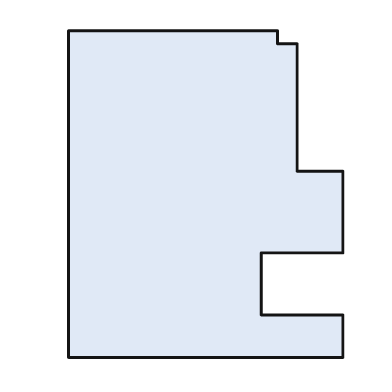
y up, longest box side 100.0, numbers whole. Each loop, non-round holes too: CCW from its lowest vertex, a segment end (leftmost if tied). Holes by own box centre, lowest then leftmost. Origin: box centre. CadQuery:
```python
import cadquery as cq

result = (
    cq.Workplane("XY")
    .moveTo(-42.0, -50.0)
    .lineTo(42.0, -50.0)
    .lineTo(42.0, -37.0)
    .lineTo(17.0, -37.0)
    .lineTo(17.0, -18.0)
    .lineTo(42.0, -18.0)
    .lineTo(42.0, 7.0)
    .lineTo(28.0, 7.0)
    .lineTo(28.0, 46.0)
    .lineTo(22.0, 46.0)
    .lineTo(22.0, 50.0)
    .lineTo(-42.0, 50.0)
    .close()
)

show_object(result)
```